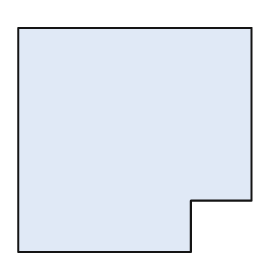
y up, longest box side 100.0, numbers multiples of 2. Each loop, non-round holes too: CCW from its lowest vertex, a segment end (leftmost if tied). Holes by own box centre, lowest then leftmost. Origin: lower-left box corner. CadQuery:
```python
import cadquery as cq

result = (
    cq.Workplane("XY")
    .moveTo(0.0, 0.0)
    .lineTo(74.0, 0.0)
    .lineTo(74.0, 22.0)
    .lineTo(100.0, 22.0)
    .lineTo(100.0, 96.0)
    .lineTo(0.0, 96.0)
    .close()
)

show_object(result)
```